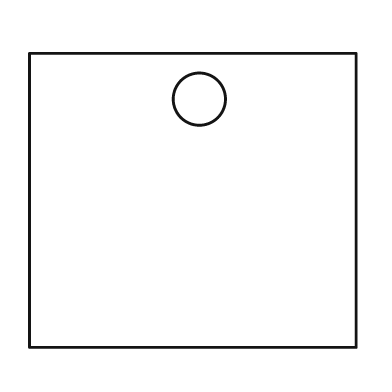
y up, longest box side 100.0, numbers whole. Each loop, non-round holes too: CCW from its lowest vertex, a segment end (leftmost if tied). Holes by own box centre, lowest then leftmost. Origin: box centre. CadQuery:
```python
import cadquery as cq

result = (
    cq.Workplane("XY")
    .moveTo(-50.0, -45.0)
    .lineTo(50.0, -45.0)
    .lineTo(50.0, 45.0)
    .lineTo(-50.0, 45.0)
    .close()
    .moveTo(2.0, 31.0)
    .circle(8.0)
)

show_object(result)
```